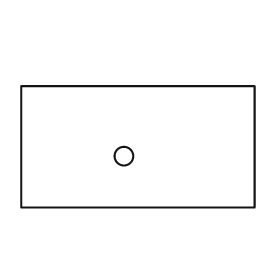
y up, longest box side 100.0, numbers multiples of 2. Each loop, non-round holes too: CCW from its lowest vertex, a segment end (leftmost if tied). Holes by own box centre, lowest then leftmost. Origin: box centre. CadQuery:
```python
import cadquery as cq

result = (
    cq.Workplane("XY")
    .moveTo(-50.0, -26.0)
    .lineTo(50.0, -26.0)
    .lineTo(50.0, 26.0)
    .lineTo(-50.0, 26.0)
    .close()
    .moveTo(-6.0, -4.0)
    .circle(4.0)
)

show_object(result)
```